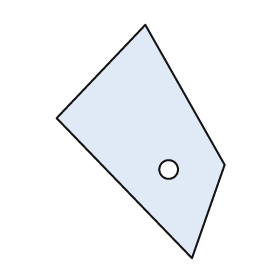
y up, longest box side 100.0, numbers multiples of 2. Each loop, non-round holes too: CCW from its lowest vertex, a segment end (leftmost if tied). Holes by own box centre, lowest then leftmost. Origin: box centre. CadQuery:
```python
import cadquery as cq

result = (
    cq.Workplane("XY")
    .moveTo(22.0, -50.0)
    .lineTo(36.0, -10.0)
    .lineTo(2.0, 50.0)
    .lineTo(-36.0, 10.0)
    .close()
    .moveTo(12.0, -12.0)
    .circle(4.0)
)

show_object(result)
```